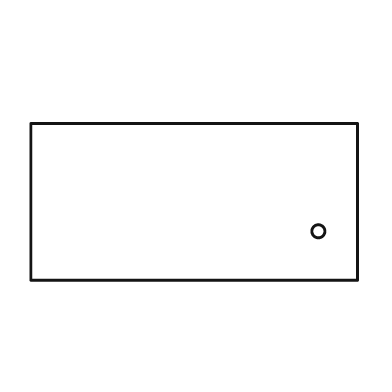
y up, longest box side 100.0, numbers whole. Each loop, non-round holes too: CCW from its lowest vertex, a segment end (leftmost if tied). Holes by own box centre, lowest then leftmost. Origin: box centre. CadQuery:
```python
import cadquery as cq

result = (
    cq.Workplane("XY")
    .moveTo(-50.0, -24.0)
    .lineTo(50.0, -24.0)
    .lineTo(50.0, 24.0)
    .lineTo(-50.0, 24.0)
    .close()
    .moveTo(38.0, -9.0)
    .circle(2.0)
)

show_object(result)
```